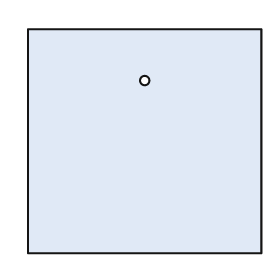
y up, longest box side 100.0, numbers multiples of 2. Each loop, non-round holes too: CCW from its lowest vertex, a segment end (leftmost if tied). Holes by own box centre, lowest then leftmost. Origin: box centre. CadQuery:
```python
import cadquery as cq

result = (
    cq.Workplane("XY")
    .moveTo(-50.0, -48.0)
    .lineTo(50.0, -48.0)
    .lineTo(50.0, 48.0)
    .lineTo(-50.0, 48.0)
    .close()
    .moveTo(0.0, 26.0)
    .circle(2.0)
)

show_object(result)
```